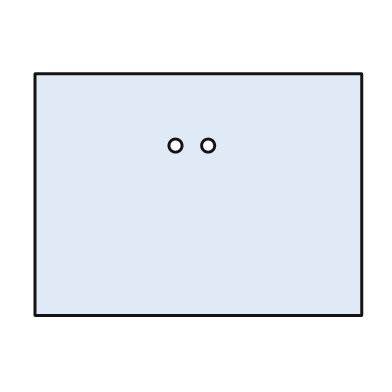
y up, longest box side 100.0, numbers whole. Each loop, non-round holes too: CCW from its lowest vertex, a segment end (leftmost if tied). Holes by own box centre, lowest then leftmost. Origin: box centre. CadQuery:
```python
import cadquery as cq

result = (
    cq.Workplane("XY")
    .moveTo(-50.0, -37.0)
    .lineTo(50.0, -37.0)
    .lineTo(50.0, 37.0)
    .lineTo(-50.0, 37.0)
    .close()
    .moveTo(-7.0, 15.0)
    .circle(2.0)
    .moveTo(3.0, 15.0)
    .circle(2.0)
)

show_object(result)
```